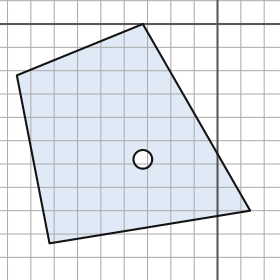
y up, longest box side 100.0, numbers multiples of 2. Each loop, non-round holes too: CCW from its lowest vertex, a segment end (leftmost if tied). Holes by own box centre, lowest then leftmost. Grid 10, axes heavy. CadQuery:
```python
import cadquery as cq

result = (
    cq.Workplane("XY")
    .moveTo(-72.0, -94.0)
    .lineTo(14.0, -80.0)
    .lineTo(-32.0, 0.0)
    .lineTo(-86.0, -22.0)
    .close()
    .moveTo(-32.0, -58.0)
    .circle(4.0)
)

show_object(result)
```